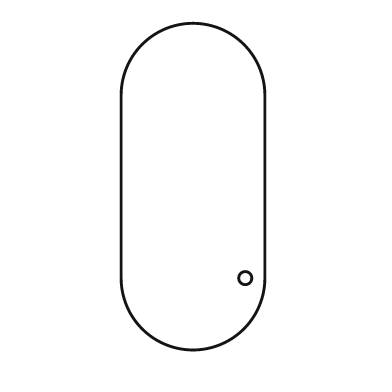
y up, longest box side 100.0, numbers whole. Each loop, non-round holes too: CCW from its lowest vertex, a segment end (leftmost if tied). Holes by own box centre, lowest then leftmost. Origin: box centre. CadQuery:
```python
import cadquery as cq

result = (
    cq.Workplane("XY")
    .moveTo(-22.0, -28.0)
    .threePointArc((0.0, -50.0), (22.0, -28.0))
    .lineTo(22.0, 28.0)
    .threePointArc((0.0, 50.0), (-22.0, 28.0))
    .close()
    .moveTo(16.0, -28.0)
    .circle(2.0)
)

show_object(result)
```